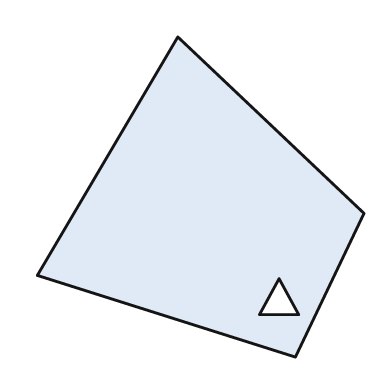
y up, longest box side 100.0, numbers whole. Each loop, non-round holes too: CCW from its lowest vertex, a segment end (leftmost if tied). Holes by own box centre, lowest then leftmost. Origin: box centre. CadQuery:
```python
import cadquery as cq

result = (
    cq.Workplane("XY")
    .moveTo(29.0, -49.0)
    .lineTo(50.0, -5.0)
    .lineTo(-7.0, 49.0)
    .lineTo(-50.0, -24.0)
    .close()
    .moveTo(18.0, -36.0)
    .lineTo(30.0, -36.0)
    .lineTo(24.0, -25.0)
    .close()
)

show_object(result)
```